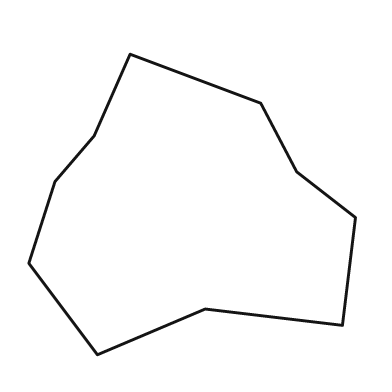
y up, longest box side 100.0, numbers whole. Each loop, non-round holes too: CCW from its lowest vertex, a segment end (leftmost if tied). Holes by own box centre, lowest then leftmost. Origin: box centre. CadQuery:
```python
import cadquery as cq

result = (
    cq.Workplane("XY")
    .moveTo(-29.0, -46.0)
    .lineTo(4.0, -32.0)
    .lineTo(46.0, -37.0)
    .lineTo(50.0, -4.0)
    .lineTo(32.0, 10.0)
    .lineTo(21.0, 31.0)
    .lineTo(-19.0, 46.0)
    .lineTo(-30.0, 21.0)
    .lineTo(-42.0, 7.0)
    .lineTo(-50.0, -18.0)
    .close()
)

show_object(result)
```